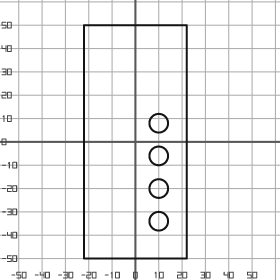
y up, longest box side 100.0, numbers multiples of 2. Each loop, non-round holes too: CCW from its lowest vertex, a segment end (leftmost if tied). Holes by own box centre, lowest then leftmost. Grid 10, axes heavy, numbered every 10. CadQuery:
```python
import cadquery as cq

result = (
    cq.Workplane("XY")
    .moveTo(-22.0, -50.0)
    .lineTo(22.0, -50.0)
    .lineTo(22.0, 50.0)
    .lineTo(-22.0, 50.0)
    .close()
    .moveTo(10.0, -34.0)
    .circle(4.0)
    .moveTo(10.0, -20.0)
    .circle(4.0)
    .moveTo(10.0, -6.0)
    .circle(4.0)
    .moveTo(10.0, 8.0)
    .circle(4.0)
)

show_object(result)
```